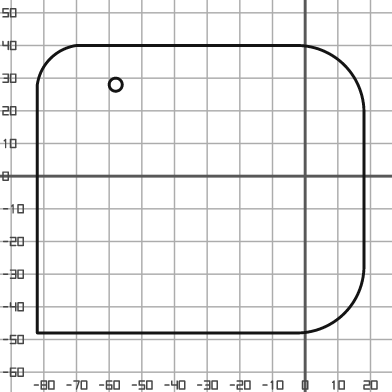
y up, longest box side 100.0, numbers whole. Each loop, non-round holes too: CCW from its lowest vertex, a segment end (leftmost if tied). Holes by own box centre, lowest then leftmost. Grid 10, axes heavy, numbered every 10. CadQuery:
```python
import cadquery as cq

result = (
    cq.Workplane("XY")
    .moveTo(-82.0, -48.0)
    .lineTo(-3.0, -48.0)
    .threePointArc((12.0, -42.0), (18.0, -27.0))
    .lineTo(18.0, 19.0)
    .threePointArc((12.0, 34.0), (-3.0, 40.0))
    .lineTo(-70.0, 40.0)
    .threePointArc((-78.0, 36.0), (-82.0, 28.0))
    .close()
    .moveTo(-58.0, 28.0)
    .circle(2.0)
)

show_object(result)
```